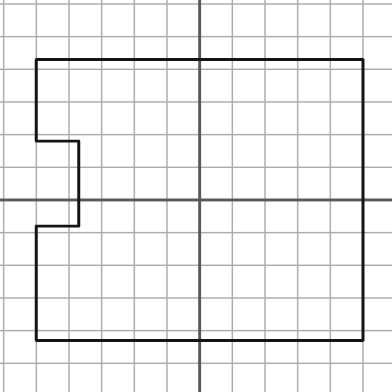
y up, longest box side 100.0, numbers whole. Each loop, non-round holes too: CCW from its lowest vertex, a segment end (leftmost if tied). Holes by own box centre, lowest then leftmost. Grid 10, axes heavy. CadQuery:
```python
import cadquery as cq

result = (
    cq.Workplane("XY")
    .moveTo(-50.0, -43.0)
    .lineTo(50.0, -43.0)
    .lineTo(50.0, 43.0)
    .lineTo(-50.0, 43.0)
    .lineTo(-50.0, 18.0)
    .lineTo(-37.0, 18.0)
    .lineTo(-37.0, -8.0)
    .lineTo(-50.0, -8.0)
    .close()
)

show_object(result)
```